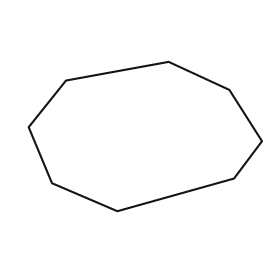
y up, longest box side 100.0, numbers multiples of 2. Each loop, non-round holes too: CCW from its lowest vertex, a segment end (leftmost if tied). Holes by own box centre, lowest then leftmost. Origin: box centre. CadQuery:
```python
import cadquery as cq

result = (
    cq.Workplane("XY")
    .moveTo(-12.0, -32.0)
    .lineTo(38.0, -18.0)
    .lineTo(50.0, -2.0)
    .lineTo(36.0, 20.0)
    .lineTo(10.0, 32.0)
    .lineTo(-34.0, 24.0)
    .lineTo(-50.0, 4.0)
    .lineTo(-40.0, -20.0)
    .close()
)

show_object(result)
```